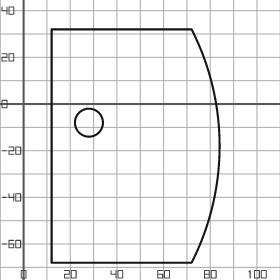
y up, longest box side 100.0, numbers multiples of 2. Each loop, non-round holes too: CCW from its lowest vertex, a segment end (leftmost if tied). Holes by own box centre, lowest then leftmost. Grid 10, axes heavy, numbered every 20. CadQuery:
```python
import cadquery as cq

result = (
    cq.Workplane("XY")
    .moveTo(12.0, -68.0)
    .lineTo(72.0, -68.0)
    .threePointArc((84.0, -18.0), (72.0, 32.0))
    .lineTo(12.0, 32.0)
    .close()
    .moveTo(28.0, -8.0)
    .circle(6.0)
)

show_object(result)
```